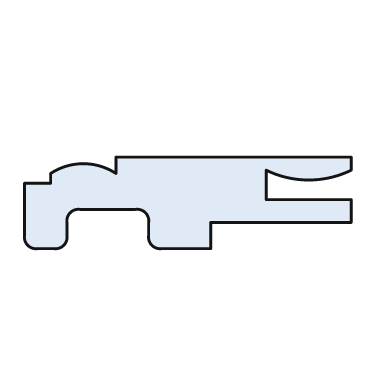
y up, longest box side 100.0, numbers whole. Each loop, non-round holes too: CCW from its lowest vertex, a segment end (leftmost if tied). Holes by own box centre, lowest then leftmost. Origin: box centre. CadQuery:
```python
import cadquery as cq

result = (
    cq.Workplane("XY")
    .moveTo(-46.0, -14.0)
    .lineTo(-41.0, -14.0)
    .threePointArc((-38.0, -13.0), (-37.0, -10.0))
    .lineTo(-37.0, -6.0)
    .threePointArc((-36.0, -3.0), (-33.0, -2.0))
    .lineTo(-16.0, -2.0)
    .threePointArc((-13.0, -3.0), (-12.0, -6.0))
    .lineTo(-12.0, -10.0)
    .threePointArc((-11.0, -13.0), (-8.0, -14.0))
    .lineTo(7.0, -14.0)
    .lineTo(7.0, -6.0)
    .lineTo(50.0, -6.0)
    .lineTo(50.0, 1.0)
    .lineTo(24.0, 1.0)
    .lineTo(24.0, 10.0)
    .threePointArc((37.0, 7.0), (50.0, 10.0))
    .lineTo(50.0, 14.0)
    .lineTo(-22.0, 14.0)
    .lineTo(-22.0, 9.0)
    .threePointArc((-32.0, 12.0), (-42.0, 9.0))
    .lineTo(-42.0, 6.0)
    .lineTo(-50.0, 6.0)
    .lineTo(-50.0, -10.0)
    .threePointArc((-49.0, -13.0), (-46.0, -14.0))
    .close()
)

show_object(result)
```